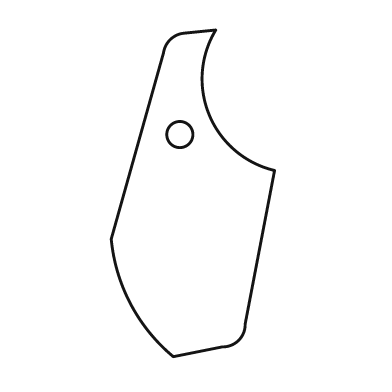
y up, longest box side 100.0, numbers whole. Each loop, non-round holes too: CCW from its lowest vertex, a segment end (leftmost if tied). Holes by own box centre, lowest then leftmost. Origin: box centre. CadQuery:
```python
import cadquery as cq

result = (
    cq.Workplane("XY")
    .moveTo(-6.0, -50.0)
    .lineTo(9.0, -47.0)
    .threePointArc((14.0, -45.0), (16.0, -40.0))
    .lineTo(25.0, 7.0)
    .threePointArc((5.0, 24.0), (7.0, 50.0))
    .lineTo(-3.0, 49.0)
    .threePointArc((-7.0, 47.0), (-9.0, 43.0))
    .lineTo(-25.0, -14.0)
    .threePointArc((-19.0, -34.0), (-6.0, -50.0))
    .close()
    .moveTo(-4.0, 18.0)
    .circle(4.0)
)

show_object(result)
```